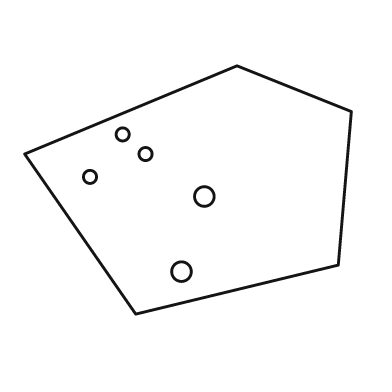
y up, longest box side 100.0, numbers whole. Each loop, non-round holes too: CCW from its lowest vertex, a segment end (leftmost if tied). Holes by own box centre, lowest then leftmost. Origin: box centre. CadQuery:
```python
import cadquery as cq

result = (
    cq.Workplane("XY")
    .moveTo(-16.0, -38.0)
    .lineTo(46.0, -23.0)
    .lineTo(50.0, 24.0)
    .lineTo(15.0, 38.0)
    .lineTo(-50.0, 11.0)
    .close()
    .moveTo(-2.0, -25.0)
    .circle(3.0)
    .moveTo(5.0, -2.0)
    .circle(3.0)
    .moveTo(-30.0, 4.0)
    .circle(2.0)
    .moveTo(-13.0, 11.0)
    .circle(2.0)
    .moveTo(-20.0, 17.0)
    .circle(2.0)
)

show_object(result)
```